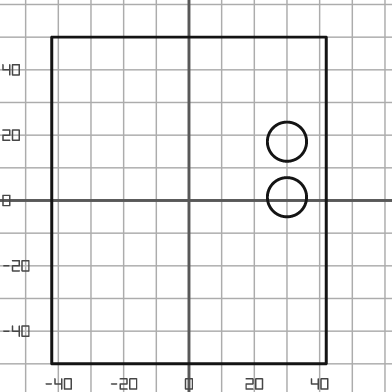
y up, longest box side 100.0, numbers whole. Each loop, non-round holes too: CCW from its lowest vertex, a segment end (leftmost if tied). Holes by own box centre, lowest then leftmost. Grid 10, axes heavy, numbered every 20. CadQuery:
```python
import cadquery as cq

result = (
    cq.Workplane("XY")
    .moveTo(-42.0, -50.0)
    .lineTo(42.0, -50.0)
    .lineTo(42.0, 50.0)
    .lineTo(-42.0, 50.0)
    .close()
    .moveTo(30.0, 1.0)
    .circle(6.0)
    .moveTo(30.0, 18.0)
    .circle(6.0)
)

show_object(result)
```